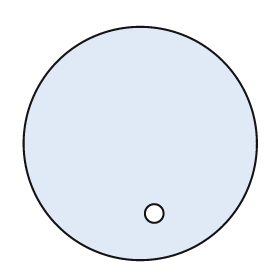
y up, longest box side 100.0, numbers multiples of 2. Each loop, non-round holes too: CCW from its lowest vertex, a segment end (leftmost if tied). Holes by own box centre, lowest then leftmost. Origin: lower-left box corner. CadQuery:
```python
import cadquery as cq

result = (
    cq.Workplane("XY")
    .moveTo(50.0, 50.0)
    .circle(50.0)
    .moveTo(56.0, 20.0)
    .circle(4.0)
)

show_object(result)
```